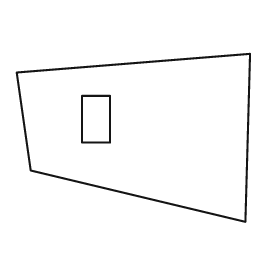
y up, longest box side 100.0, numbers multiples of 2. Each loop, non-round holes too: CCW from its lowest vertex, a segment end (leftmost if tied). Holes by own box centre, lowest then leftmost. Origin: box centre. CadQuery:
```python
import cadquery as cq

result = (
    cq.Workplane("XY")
    .moveTo(48.0, -36.0)
    .lineTo(50.0, 36.0)
    .lineTo(-50.0, 28.0)
    .lineTo(-44.0, -14.0)
    .close()
    .moveTo(-22.0, -2.0)
    .lineTo(-10.0, -2.0)
    .lineTo(-10.0, 18.0)
    .lineTo(-22.0, 18.0)
    .close()
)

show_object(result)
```